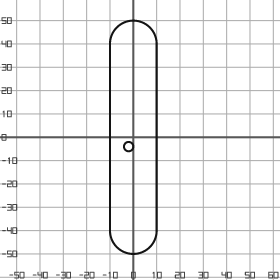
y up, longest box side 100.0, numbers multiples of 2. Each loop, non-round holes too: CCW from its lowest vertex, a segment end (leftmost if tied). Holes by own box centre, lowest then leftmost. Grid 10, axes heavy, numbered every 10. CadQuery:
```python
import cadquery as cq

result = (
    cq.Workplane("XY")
    .moveTo(-10.0, -40.0)
    .threePointArc((0.0, -50.0), (10.0, -40.0))
    .lineTo(10.0, 40.0)
    .threePointArc((0.0, 50.0), (-10.0, 40.0))
    .close()
    .moveTo(-2.0, -4.0)
    .circle(2.0)
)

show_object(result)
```